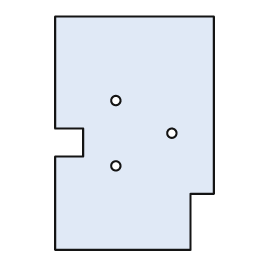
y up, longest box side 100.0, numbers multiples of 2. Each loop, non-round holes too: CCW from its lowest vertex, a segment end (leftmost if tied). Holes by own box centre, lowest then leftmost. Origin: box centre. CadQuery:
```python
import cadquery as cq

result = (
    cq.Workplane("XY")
    .moveTo(-34.0, -50.0)
    .lineTo(24.0, -50.0)
    .lineTo(24.0, -26.0)
    .lineTo(34.0, -26.0)
    .lineTo(34.0, 50.0)
    .lineTo(-34.0, 50.0)
    .lineTo(-34.0, 2.0)
    .lineTo(-22.0, 2.0)
    .lineTo(-22.0, -10.0)
    .lineTo(-34.0, -10.0)
    .close()
    .moveTo(-8.0, -14.0)
    .circle(2.0)
    .moveTo(16.0, 0.0)
    .circle(2.0)
    .moveTo(-8.0, 14.0)
    .circle(2.0)
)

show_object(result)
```